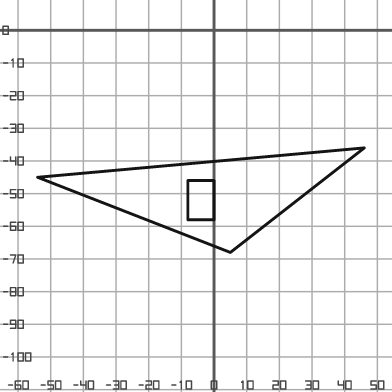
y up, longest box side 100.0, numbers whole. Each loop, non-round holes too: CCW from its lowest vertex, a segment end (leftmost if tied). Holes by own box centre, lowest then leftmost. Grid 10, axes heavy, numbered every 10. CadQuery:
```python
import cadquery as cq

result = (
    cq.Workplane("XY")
    .moveTo(5.0, -68.0)
    .lineTo(46.0, -36.0)
    .lineTo(-54.0, -45.0)
    .close()
    .moveTo(-8.0, -58.0)
    .lineTo(0.0, -58.0)
    .lineTo(0.0, -46.0)
    .lineTo(-8.0, -46.0)
    .close()
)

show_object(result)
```